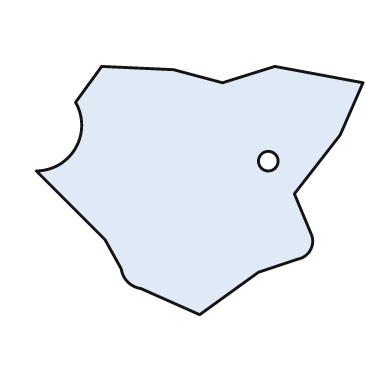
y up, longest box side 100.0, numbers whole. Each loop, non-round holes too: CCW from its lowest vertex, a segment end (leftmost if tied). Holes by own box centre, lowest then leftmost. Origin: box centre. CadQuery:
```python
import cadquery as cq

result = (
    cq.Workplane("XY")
    .moveTo(0.0, -38.0)
    .lineTo(18.0, -25.0)
    .lineTo(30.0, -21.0)
    .threePointArc((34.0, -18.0), (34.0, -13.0))
    .lineTo(29.0, -1.0)
    .lineTo(43.0, 17.0)
    .lineTo(50.0, 33.0)
    .lineTo(23.0, 38.0)
    .lineTo(7.0, 33.0)
    .lineTo(-8.0, 37.0)
    .lineTo(-30.0, 38.0)
    .lineTo(-38.0, 27.0)
    .threePointArc((-38.0, 13.0), (-50.0, 6.0))
    .lineTo(-29.0, -15.0)
    .lineTo(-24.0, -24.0)
    .threePointArc((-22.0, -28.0), (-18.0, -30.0))
    .close()
    .moveTo(21.0, 9.0)
    .circle(3.0)
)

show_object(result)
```